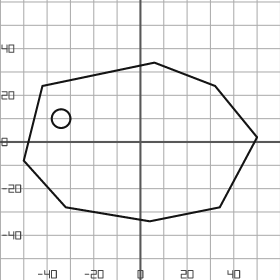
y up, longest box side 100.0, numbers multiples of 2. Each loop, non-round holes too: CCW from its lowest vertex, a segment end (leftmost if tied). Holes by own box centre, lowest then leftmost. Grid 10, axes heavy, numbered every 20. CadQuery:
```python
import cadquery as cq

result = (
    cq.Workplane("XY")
    .moveTo(4.0, -34.0)
    .lineTo(34.0, -28.0)
    .lineTo(50.0, 2.0)
    .lineTo(32.0, 24.0)
    .lineTo(6.0, 34.0)
    .lineTo(-42.0, 24.0)
    .lineTo(-50.0, -8.0)
    .lineTo(-32.0, -28.0)
    .close()
    .moveTo(-34.0, 10.0)
    .circle(4.0)
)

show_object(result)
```